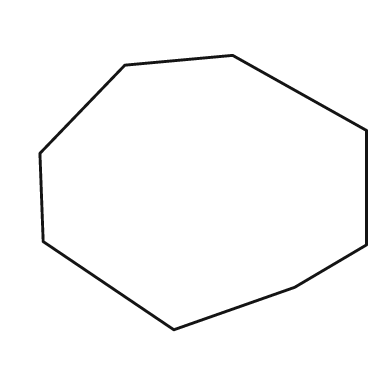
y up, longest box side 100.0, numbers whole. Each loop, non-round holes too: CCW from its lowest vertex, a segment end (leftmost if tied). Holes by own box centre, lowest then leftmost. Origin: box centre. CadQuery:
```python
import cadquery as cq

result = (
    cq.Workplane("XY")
    .moveTo(-9.0, -42.0)
    .lineTo(28.0, -29.0)
    .lineTo(50.0, -16.0)
    .lineTo(50.0, 19.0)
    .lineTo(9.0, 42.0)
    .lineTo(-24.0, 39.0)
    .lineTo(-50.0, 12.0)
    .lineTo(-49.0, -15.0)
    .close()
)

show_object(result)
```